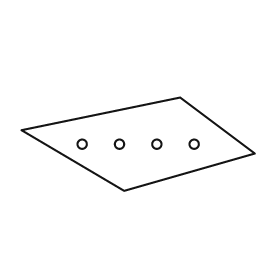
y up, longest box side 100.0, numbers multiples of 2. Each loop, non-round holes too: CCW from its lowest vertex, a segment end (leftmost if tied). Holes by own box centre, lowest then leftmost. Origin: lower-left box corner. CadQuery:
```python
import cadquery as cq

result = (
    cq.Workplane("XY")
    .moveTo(44.0, 0.0)
    .lineTo(100.0, 16.0)
    .lineTo(68.0, 40.0)
    .lineTo(0.0, 26.0)
    .close()
    .moveTo(26.0, 20.0)
    .circle(2.0)
    .moveTo(42.0, 20.0)
    .circle(2.0)
    .moveTo(58.0, 20.0)
    .circle(2.0)
    .moveTo(74.0, 20.0)
    .circle(2.0)
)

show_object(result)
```